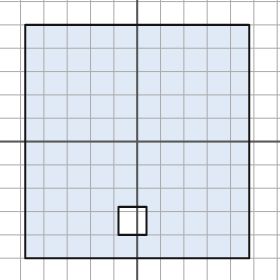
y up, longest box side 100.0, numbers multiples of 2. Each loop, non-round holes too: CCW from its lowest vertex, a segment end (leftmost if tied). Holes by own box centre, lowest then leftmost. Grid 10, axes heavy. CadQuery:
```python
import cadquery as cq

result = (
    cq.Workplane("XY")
    .moveTo(-48.0, -50.0)
    .lineTo(48.0, -50.0)
    .lineTo(48.0, 50.0)
    .lineTo(-48.0, 50.0)
    .close()
    .moveTo(-8.0, -40.0)
    .lineTo(4.0, -40.0)
    .lineTo(4.0, -28.0)
    .lineTo(-8.0, -28.0)
    .close()
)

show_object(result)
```